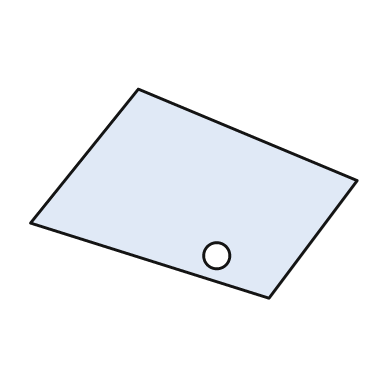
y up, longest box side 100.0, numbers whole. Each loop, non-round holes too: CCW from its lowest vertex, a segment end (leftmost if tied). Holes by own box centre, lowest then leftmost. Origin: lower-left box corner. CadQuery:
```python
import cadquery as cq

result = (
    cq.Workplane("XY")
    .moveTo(73.0, 0.0)
    .lineTo(100.0, 36.0)
    .lineTo(33.0, 64.0)
    .lineTo(0.0, 23.0)
    .close()
    .moveTo(57.0, 13.0)
    .circle(4.0)
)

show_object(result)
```